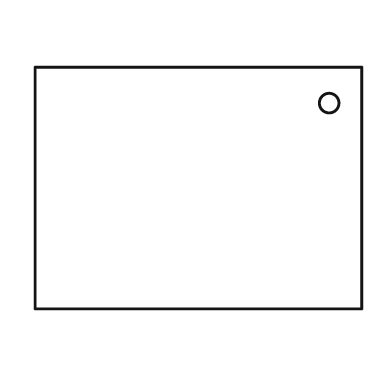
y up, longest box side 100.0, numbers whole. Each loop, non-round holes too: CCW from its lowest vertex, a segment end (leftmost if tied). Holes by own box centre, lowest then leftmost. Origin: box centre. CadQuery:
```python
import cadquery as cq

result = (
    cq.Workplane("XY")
    .moveTo(-50.0, -37.0)
    .lineTo(50.0, -37.0)
    .lineTo(50.0, 37.0)
    .lineTo(-50.0, 37.0)
    .close()
    .moveTo(40.0, 26.0)
    .circle(3.0)
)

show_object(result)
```